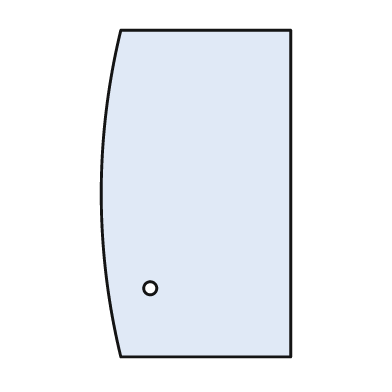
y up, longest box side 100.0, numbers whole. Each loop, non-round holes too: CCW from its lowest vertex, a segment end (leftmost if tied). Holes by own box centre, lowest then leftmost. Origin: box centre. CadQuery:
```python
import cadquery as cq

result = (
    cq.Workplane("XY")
    .moveTo(-23.0, -50.0)
    .lineTo(29.0, -50.0)
    .lineTo(29.0, 50.0)
    .lineTo(-23.0, 50.0)
    .threePointArc((-29.0, 0.0), (-23.0, -50.0))
    .close()
    .moveTo(-14.0, -29.0)
    .circle(2.0)
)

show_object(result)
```